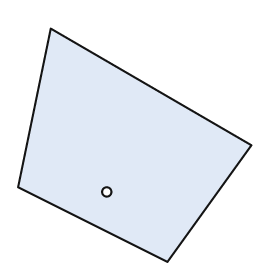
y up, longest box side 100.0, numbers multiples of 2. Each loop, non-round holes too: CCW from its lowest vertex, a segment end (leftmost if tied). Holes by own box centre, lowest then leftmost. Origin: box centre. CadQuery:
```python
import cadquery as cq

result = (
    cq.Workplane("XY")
    .moveTo(14.0, -50.0)
    .lineTo(50.0, 0.0)
    .lineTo(-36.0, 50.0)
    .lineTo(-50.0, -18.0)
    .close()
    .moveTo(-12.0, -20.0)
    .circle(2.0)
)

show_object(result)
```